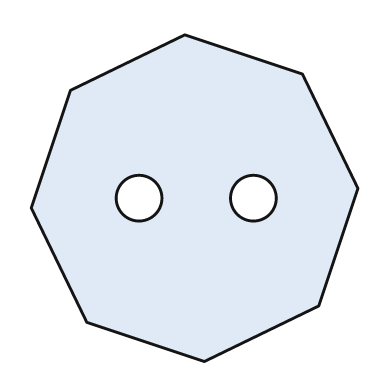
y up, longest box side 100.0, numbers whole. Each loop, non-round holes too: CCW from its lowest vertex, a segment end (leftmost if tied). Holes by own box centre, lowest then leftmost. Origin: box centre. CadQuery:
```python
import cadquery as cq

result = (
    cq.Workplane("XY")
    .moveTo(3.0, -50.0)
    .lineTo(38.0, -33.0)
    .lineTo(50.0, 3.0)
    .lineTo(33.0, 38.0)
    .lineTo(-3.0, 50.0)
    .lineTo(-38.0, 33.0)
    .lineTo(-50.0, -3.0)
    .lineTo(-33.0, -38.0)
    .close()
    .moveTo(-17.0, 0.0)
    .circle(7.0)
    .moveTo(18.0, 0.0)
    .circle(7.0)
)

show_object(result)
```